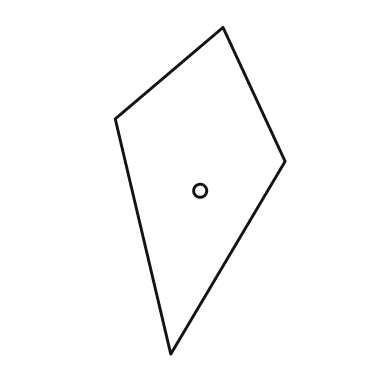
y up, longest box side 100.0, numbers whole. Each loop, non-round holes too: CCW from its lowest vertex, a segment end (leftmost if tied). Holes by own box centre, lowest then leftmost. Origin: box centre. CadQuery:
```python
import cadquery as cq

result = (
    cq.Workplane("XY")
    .moveTo(-9.0, -50.0)
    .lineTo(26.0, 9.0)
    .lineTo(7.0, 50.0)
    .lineTo(-26.0, 22.0)
    .close()
    .moveTo(0.0, 0.0)
    .circle(2.0)
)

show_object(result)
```